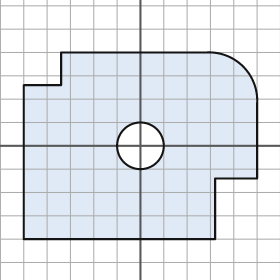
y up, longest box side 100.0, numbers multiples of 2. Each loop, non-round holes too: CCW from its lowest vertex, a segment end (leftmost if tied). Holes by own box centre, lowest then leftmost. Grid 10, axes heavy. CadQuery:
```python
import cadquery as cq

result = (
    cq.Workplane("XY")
    .moveTo(-50.0, -40.0)
    .lineTo(32.0, -40.0)
    .lineTo(32.0, -14.0)
    .lineTo(50.0, -14.0)
    .lineTo(50.0, 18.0)
    .threePointArc((44.0, 34.0), (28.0, 40.0))
    .lineTo(-34.0, 40.0)
    .lineTo(-34.0, 26.0)
    .lineTo(-50.0, 26.0)
    .close()
    .moveTo(0.0, 0.0)
    .circle(10.0)
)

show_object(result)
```